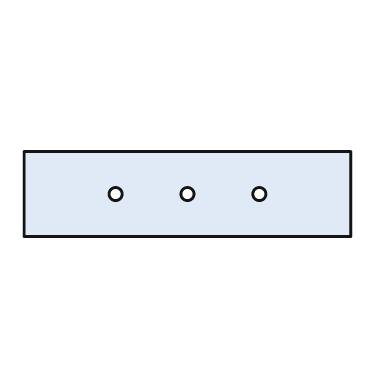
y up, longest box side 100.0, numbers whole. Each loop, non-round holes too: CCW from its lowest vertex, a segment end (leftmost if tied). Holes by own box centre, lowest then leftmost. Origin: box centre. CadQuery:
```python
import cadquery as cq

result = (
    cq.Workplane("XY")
    .moveTo(-50.0, -13.0)
    .lineTo(50.0, -13.0)
    .lineTo(50.0, 13.0)
    .lineTo(-50.0, 13.0)
    .close()
    .moveTo(-22.0, 0.0)
    .circle(2.0)
    .moveTo(0.0, 0.0)
    .circle(2.0)
    .moveTo(22.0, 0.0)
    .circle(2.0)
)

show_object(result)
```